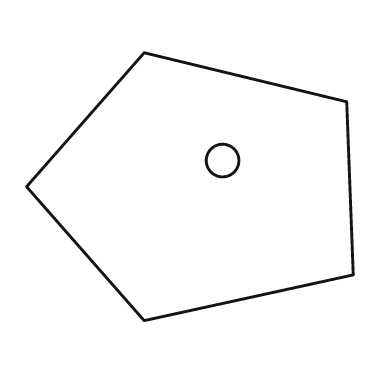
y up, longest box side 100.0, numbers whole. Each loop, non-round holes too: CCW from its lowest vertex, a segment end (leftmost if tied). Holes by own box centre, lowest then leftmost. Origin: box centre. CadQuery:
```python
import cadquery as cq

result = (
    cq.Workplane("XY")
    .moveTo(-14.0, -41.0)
    .lineTo(50.0, -27.0)
    .lineTo(48.0, 26.0)
    .lineTo(-14.0, 41.0)
    .lineTo(-50.0, 0.0)
    .close()
    .moveTo(10.0, 8.0)
    .circle(5.0)
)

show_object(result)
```